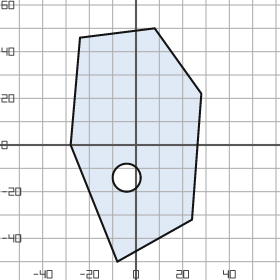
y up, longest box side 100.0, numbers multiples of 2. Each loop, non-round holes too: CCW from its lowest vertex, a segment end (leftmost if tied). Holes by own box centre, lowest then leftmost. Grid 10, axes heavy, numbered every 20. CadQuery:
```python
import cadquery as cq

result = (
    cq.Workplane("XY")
    .moveTo(-8.0, -50.0)
    .lineTo(24.0, -32.0)
    .lineTo(28.0, 22.0)
    .lineTo(8.0, 50.0)
    .lineTo(-24.0, 46.0)
    .lineTo(-28.0, 0.0)
    .close()
    .moveTo(-4.0, -14.0)
    .circle(6.0)
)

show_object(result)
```